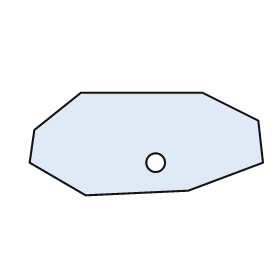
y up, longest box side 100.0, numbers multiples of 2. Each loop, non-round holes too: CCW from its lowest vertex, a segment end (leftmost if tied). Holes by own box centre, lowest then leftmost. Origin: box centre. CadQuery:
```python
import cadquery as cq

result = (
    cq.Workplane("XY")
    .moveTo(-26.0, -22.0)
    .lineTo(18.0, -20.0)
    .lineTo(50.0, -8.0)
    .lineTo(48.0, 10.0)
    .lineTo(24.0, 22.0)
    .lineTo(-28.0, 22.0)
    .lineTo(-48.0, 6.0)
    .lineTo(-50.0, -8.0)
    .close()
    .moveTo(4.0, -8.0)
    .circle(4.0)
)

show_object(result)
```